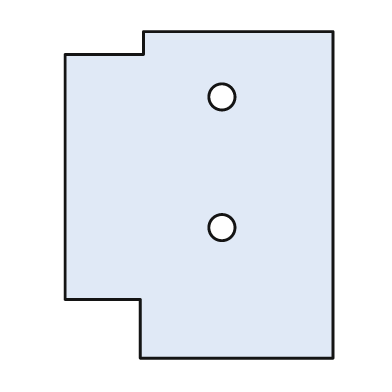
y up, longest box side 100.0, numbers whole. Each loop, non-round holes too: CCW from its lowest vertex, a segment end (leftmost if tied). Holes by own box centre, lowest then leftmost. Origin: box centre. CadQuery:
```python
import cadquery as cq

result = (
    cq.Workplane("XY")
    .moveTo(-18.0, -50.0)
    .lineTo(41.0, -50.0)
    .lineTo(41.0, 50.0)
    .lineTo(-17.0, 50.0)
    .lineTo(-17.0, 43.0)
    .lineTo(-41.0, 43.0)
    .lineTo(-41.0, -32.0)
    .lineTo(-18.0, -32.0)
    .close()
    .moveTo(7.0, -10.0)
    .circle(4.0)
    .moveTo(7.0, 30.0)
    .circle(4.0)
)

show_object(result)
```